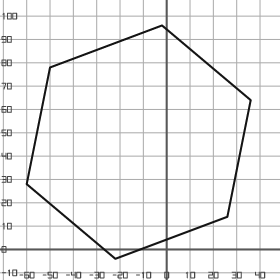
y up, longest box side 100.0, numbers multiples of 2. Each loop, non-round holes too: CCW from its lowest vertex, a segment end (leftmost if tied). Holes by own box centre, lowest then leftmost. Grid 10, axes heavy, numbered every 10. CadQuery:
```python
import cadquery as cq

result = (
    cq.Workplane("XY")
    .moveTo(-22.0, -4.0)
    .lineTo(26.0, 14.0)
    .lineTo(36.0, 64.0)
    .lineTo(-2.0, 96.0)
    .lineTo(-50.0, 78.0)
    .lineTo(-60.0, 28.0)
    .close()
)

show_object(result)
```